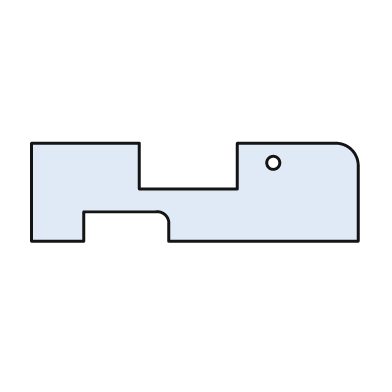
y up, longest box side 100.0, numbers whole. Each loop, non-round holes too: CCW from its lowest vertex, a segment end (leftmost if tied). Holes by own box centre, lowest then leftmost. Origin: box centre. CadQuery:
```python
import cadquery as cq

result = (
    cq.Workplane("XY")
    .moveTo(-50.0, -15.0)
    .lineTo(-34.0, -15.0)
    .lineTo(-34.0, -6.0)
    .lineTo(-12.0, -6.0)
    .threePointArc((-9.0, -7.0), (-8.0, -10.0))
    .lineTo(-8.0, -15.0)
    .lineTo(50.0, -15.0)
    .lineTo(50.0, 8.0)
    .threePointArc((48.0, 13.0), (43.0, 15.0))
    .lineTo(13.0, 15.0)
    .lineTo(13.0, 1.0)
    .lineTo(-17.0, 1.0)
    .lineTo(-17.0, 15.0)
    .lineTo(-50.0, 15.0)
    .close()
    .moveTo(24.0, 9.0)
    .circle(2.0)
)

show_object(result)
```